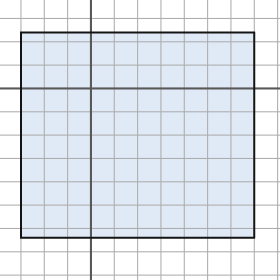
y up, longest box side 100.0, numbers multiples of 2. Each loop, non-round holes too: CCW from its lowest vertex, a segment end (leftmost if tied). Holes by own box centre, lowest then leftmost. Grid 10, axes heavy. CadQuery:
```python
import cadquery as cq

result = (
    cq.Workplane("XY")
    .moveTo(-30.0, -64.0)
    .lineTo(70.0, -64.0)
    .lineTo(70.0, 24.0)
    .lineTo(-30.0, 24.0)
    .close()
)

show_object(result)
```